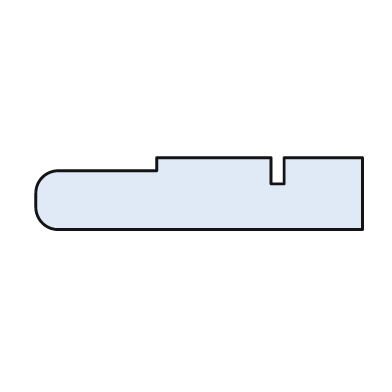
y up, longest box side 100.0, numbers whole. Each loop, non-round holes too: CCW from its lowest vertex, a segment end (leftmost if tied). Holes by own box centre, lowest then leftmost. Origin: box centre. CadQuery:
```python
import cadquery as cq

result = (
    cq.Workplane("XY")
    .moveTo(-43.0, -11.0)
    .lineTo(50.0, -11.0)
    .lineTo(50.0, 11.0)
    .lineTo(26.0, 11.0)
    .lineTo(26.0, 3.0)
    .lineTo(22.0, 3.0)
    .lineTo(22.0, 11.0)
    .lineTo(-13.0, 11.0)
    .lineTo(-13.0, 7.0)
    .lineTo(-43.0, 7.0)
    .threePointArc((-48.0, 5.0), (-50.0, 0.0))
    .lineTo(-50.0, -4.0)
    .threePointArc((-48.0, -9.0), (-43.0, -11.0))
    .close()
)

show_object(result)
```